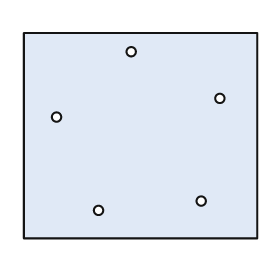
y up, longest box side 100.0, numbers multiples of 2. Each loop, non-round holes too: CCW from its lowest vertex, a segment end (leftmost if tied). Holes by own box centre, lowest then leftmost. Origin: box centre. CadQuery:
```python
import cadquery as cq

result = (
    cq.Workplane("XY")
    .moveTo(-50.0, -44.0)
    .lineTo(50.0, -44.0)
    .lineTo(50.0, 44.0)
    .lineTo(-50.0, 44.0)
    .close()
    .moveTo(-18.0, -32.0)
    .circle(2.0)
    .moveTo(26.0, -28.0)
    .circle(2.0)
    .moveTo(-36.0, 8.0)
    .circle(2.0)
    .moveTo(34.0, 16.0)
    .circle(2.0)
    .moveTo(-4.0, 36.0)
    .circle(2.0)
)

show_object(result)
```